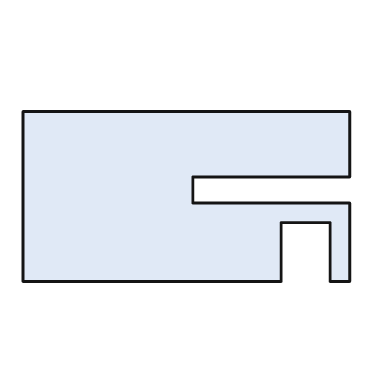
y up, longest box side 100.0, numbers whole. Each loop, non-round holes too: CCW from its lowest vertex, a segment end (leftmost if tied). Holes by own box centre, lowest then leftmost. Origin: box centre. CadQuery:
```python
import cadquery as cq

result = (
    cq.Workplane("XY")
    .moveTo(-50.0, -26.0)
    .lineTo(29.0, -26.0)
    .lineTo(29.0, -8.0)
    .lineTo(44.0, -8.0)
    .lineTo(44.0, -26.0)
    .lineTo(50.0, -26.0)
    .lineTo(50.0, -2.0)
    .lineTo(2.0, -2.0)
    .lineTo(2.0, 6.0)
    .lineTo(50.0, 6.0)
    .lineTo(50.0, 26.0)
    .lineTo(-50.0, 26.0)
    .close()
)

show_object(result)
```